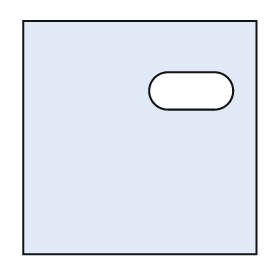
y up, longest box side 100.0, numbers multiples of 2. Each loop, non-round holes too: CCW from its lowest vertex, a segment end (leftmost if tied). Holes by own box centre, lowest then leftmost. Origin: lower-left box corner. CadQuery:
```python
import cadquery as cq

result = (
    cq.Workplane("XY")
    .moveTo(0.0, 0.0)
    .lineTo(100.0, 0.0)
    .lineTo(100.0, 100.0)
    .lineTo(0.0, 100.0)
    .close()
    .moveTo(62.0, 62.0)
    .lineTo(82.0, 62.0)
    .threePointArc((90.0, 70.0), (82.0, 78.0))
    .lineTo(62.0, 78.0)
    .threePointArc((54.0, 70.0), (62.0, 62.0))
    .close()
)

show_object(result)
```